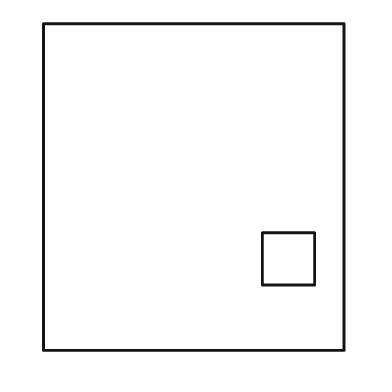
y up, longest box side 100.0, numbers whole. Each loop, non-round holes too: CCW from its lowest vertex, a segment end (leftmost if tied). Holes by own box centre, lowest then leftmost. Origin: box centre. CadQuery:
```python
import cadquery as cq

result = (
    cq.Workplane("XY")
    .moveTo(-46.0, -50.0)
    .lineTo(46.0, -50.0)
    .lineTo(46.0, 50.0)
    .lineTo(-46.0, 50.0)
    .close()
    .moveTo(21.0, -30.0)
    .lineTo(37.0, -30.0)
    .lineTo(37.0, -14.0)
    .lineTo(21.0, -14.0)
    .close()
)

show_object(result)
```